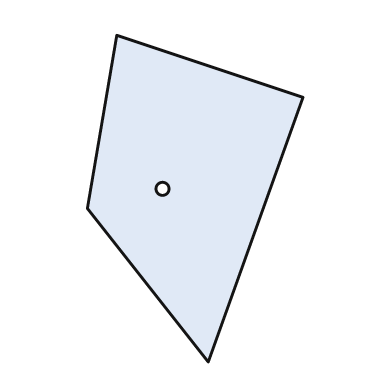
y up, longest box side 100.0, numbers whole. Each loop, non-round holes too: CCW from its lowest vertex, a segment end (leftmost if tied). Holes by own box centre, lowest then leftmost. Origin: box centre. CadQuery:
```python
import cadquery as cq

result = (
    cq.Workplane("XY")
    .moveTo(4.0, -50.0)
    .lineTo(33.0, 31.0)
    .lineTo(-24.0, 50.0)
    .lineTo(-33.0, -3.0)
    .close()
    .moveTo(-10.0, 3.0)
    .circle(2.0)
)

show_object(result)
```